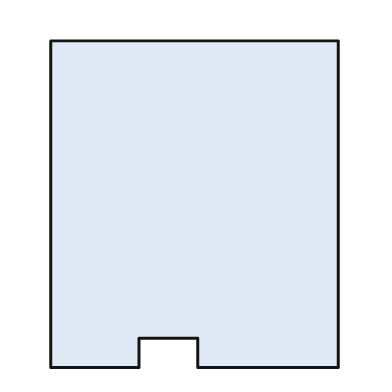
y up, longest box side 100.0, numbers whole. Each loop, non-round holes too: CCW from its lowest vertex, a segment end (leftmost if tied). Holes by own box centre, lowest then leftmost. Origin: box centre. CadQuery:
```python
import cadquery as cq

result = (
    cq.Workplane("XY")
    .moveTo(-44.0, -50.0)
    .lineTo(-17.0, -50.0)
    .lineTo(-17.0, -41.0)
    .lineTo(1.0, -41.0)
    .lineTo(1.0, -50.0)
    .lineTo(44.0, -50.0)
    .lineTo(44.0, 50.0)
    .lineTo(-44.0, 50.0)
    .close()
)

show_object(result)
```